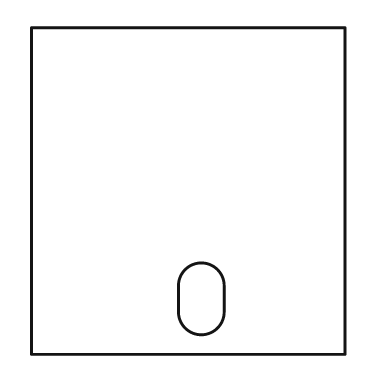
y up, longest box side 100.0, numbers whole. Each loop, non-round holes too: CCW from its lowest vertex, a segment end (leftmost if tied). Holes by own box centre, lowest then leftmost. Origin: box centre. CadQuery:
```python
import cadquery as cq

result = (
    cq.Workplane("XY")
    .moveTo(-48.0, -50.0)
    .lineTo(48.0, -50.0)
    .lineTo(48.0, 50.0)
    .lineTo(-48.0, 50.0)
    .close()
    .moveTo(-3.0, -37.0)
    .threePointArc((4.0, -44.0), (11.0, -37.0))
    .lineTo(11.0, -29.0)
    .threePointArc((4.0, -22.0), (-3.0, -29.0))
    .close()
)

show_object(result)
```